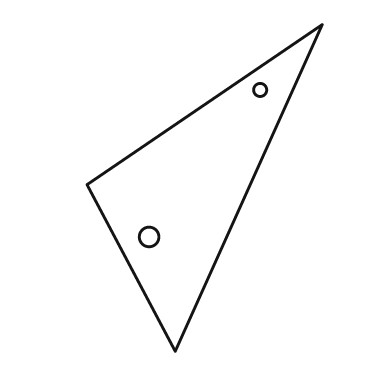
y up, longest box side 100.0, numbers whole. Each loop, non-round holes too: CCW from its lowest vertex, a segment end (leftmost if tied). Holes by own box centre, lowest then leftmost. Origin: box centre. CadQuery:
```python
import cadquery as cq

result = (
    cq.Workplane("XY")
    .moveTo(-9.0, -50.0)
    .lineTo(36.0, 50.0)
    .lineTo(-36.0, 1.0)
    .close()
    .moveTo(-17.0, -15.0)
    .circle(3.0)
    .moveTo(17.0, 30.0)
    .circle(2.0)
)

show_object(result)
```